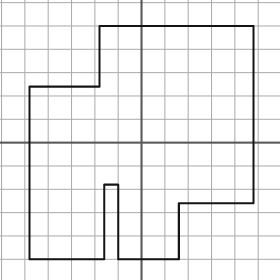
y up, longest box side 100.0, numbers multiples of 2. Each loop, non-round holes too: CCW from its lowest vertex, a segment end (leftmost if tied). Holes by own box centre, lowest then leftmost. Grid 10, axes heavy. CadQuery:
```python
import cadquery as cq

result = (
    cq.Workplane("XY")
    .moveTo(-48.0, -50.0)
    .lineTo(-16.0, -50.0)
    .lineTo(-16.0, -18.0)
    .lineTo(-10.0, -18.0)
    .lineTo(-10.0, -50.0)
    .lineTo(16.0, -50.0)
    .lineTo(16.0, -26.0)
    .lineTo(48.0, -26.0)
    .lineTo(48.0, 50.0)
    .lineTo(-18.0, 50.0)
    .lineTo(-18.0, 24.0)
    .lineTo(-48.0, 24.0)
    .close()
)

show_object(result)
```